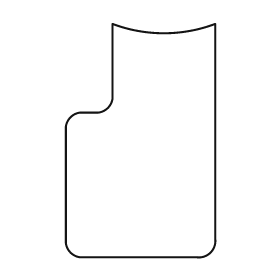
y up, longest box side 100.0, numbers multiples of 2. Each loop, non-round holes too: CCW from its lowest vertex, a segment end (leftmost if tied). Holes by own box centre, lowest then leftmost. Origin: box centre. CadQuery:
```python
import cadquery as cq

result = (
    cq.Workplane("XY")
    .moveTo(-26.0, -50.0)
    .lineTo(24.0, -50.0)
    .threePointArc((30.0, -48.0), (32.0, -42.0))
    .lineTo(32.0, 50.0)
    .threePointArc((10.0, 46.0), (-12.0, 50.0))
    .lineTo(-12.0, 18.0)
    .threePointArc((-14.0, 14.0), (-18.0, 12.0))
    .lineTo(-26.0, 12.0)
    .threePointArc((-30.0, 10.0), (-32.0, 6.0))
    .lineTo(-32.0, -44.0)
    .threePointArc((-30.0, -48.0), (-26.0, -50.0))
    .close()
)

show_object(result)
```